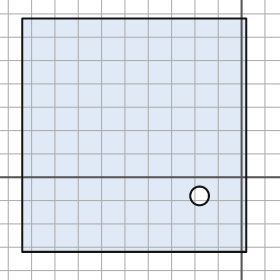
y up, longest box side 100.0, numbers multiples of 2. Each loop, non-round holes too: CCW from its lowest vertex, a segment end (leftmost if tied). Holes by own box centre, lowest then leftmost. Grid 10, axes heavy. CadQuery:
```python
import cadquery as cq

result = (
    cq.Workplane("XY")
    .moveTo(-94.0, -32.0)
    .lineTo(2.0, -32.0)
    .lineTo(2.0, 68.0)
    .lineTo(-94.0, 68.0)
    .close()
    .moveTo(-18.0, -8.0)
    .circle(4.0)
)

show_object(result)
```